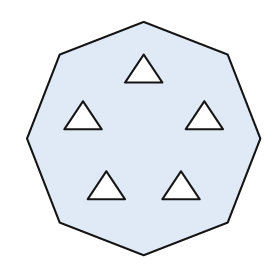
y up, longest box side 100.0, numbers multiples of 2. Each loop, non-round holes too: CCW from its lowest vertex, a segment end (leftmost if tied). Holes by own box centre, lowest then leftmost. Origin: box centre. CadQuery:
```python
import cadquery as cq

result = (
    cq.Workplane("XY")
    .moveTo(0.0, -50.0)
    .lineTo(36.0, -36.0)
    .lineTo(50.0, 0.0)
    .lineTo(36.0, 36.0)
    .lineTo(0.0, 50.0)
    .lineTo(-36.0, 36.0)
    .lineTo(-50.0, 0.0)
    .lineTo(-36.0, -36.0)
    .close()
    .moveTo(-24.0, -26.0)
    .lineTo(-8.0, -26.0)
    .lineTo(-16.0, -14.0)
    .close()
    .moveTo(8.0, -26.0)
    .lineTo(24.0, -26.0)
    .lineTo(16.0, -14.0)
    .close()
    .moveTo(-34.0, 4.0)
    .lineTo(-18.0, 4.0)
    .lineTo(-26.0, 16.0)
    .close()
    .moveTo(18.0, 4.0)
    .lineTo(34.0, 4.0)
    .lineTo(26.0, 16.0)
    .close()
    .moveTo(-8.0, 24.0)
    .lineTo(8.0, 24.0)
    .lineTo(0.0, 36.0)
    .close()
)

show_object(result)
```